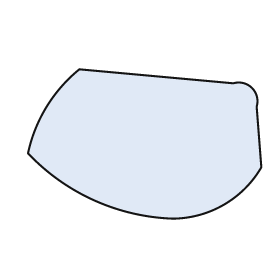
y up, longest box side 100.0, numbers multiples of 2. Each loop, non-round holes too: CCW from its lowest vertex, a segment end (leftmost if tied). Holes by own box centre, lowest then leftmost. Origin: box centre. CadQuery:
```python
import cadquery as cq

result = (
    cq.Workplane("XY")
    .moveTo(12.0, -32.0)
    .threePointArc((34.0, -26.0), (50.0, -10.0))
    .lineTo(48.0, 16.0)
    .threePointArc((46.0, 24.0), (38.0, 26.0))
    .lineTo(-28.0, 32.0)
    .threePointArc((-42.0, 16.0), (-50.0, -4.0))
    .threePointArc((-22.0, -24.0), (12.0, -32.0))
    .close()
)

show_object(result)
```